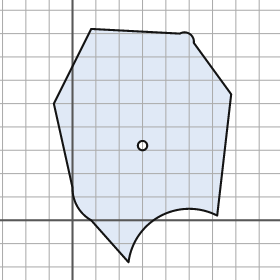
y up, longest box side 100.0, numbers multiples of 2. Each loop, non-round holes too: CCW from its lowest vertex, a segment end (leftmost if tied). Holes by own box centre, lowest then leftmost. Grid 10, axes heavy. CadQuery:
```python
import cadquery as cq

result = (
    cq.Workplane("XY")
    .moveTo(24.0, -18.0)
    .threePointArc((38.0, 2.0), (62.0, 2.0))
    .lineTo(68.0, 54.0)
    .lineTo(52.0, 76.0)
    .threePointArc((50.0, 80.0), (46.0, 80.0))
    .lineTo(8.0, 82.0)
    .lineTo(-8.0, 50.0)
    .lineTo(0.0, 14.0)
    .threePointArc((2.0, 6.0), (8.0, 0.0))
    .close()
    .moveTo(30.0, 32.0)
    .circle(2.0)
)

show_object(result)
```